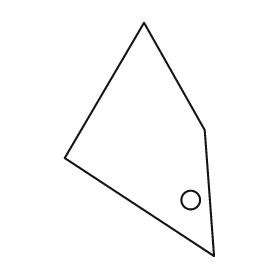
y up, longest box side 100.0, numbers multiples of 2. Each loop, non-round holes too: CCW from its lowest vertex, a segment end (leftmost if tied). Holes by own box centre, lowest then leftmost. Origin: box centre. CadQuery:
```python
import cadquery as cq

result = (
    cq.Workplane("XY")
    .moveTo(32.0, -50.0)
    .lineTo(28.0, 4.0)
    .lineTo(2.0, 50.0)
    .lineTo(-32.0, -8.0)
    .close()
    .moveTo(22.0, -26.0)
    .circle(4.0)
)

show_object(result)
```